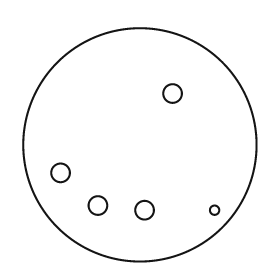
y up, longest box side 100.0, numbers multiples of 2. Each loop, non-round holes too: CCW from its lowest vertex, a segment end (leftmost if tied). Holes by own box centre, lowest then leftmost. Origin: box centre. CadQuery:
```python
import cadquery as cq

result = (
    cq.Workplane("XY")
    .moveTo(0.0, 0.0)
    .circle(50.0)
    .moveTo(2.0, -28.0)
    .circle(4.0)
    .moveTo(32.0, -28.0)
    .circle(2.0)
    .moveTo(-18.0, -26.0)
    .circle(4.0)
    .moveTo(-34.0, -12.0)
    .circle(4.0)
    .moveTo(14.0, 22.0)
    .circle(4.0)
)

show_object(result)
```